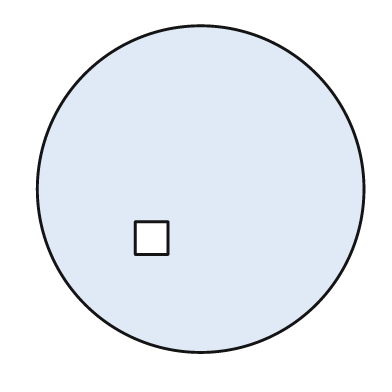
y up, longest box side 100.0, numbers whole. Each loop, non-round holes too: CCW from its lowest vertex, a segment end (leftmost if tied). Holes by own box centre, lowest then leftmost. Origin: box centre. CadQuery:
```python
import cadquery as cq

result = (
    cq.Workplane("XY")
    .moveTo(0.0, 0.0)
    .circle(50.0)
    .moveTo(-20.0, -20.0)
    .lineTo(-10.0, -20.0)
    .lineTo(-10.0, -10.0)
    .lineTo(-20.0, -10.0)
    .close()
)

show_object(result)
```